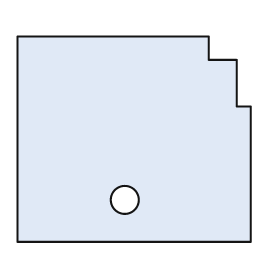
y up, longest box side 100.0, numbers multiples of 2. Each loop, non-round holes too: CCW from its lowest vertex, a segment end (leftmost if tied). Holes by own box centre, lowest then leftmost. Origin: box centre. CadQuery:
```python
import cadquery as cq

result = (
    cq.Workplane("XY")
    .moveTo(-50.0, -44.0)
    .lineTo(50.0, -44.0)
    .lineTo(50.0, 14.0)
    .lineTo(44.0, 14.0)
    .lineTo(44.0, 34.0)
    .lineTo(32.0, 34.0)
    .lineTo(32.0, 44.0)
    .lineTo(-50.0, 44.0)
    .close()
    .moveTo(-4.0, -26.0)
    .circle(6.0)
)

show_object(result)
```